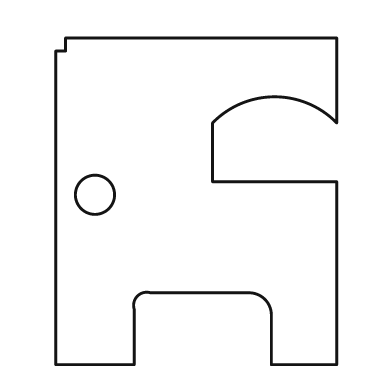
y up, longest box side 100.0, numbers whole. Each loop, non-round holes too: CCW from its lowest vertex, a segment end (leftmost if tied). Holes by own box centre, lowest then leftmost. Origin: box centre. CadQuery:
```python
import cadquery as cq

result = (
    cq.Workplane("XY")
    .moveTo(-43.0, -50.0)
    .lineTo(-19.0, -50.0)
    .lineTo(-19.0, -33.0)
    .threePointArc((-18.0, -29.0), (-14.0, -28.0))
    .lineTo(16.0, -28.0)
    .threePointArc((21.0, -30.0), (23.0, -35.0))
    .lineTo(23.0, -50.0)
    .lineTo(43.0, -50.0)
    .lineTo(43.0, 6.0)
    .lineTo(5.0, 6.0)
    .lineTo(5.0, 24.0)
    .threePointArc((24.0, 32.0), (43.0, 24.0))
    .lineTo(43.0, 50.0)
    .lineTo(-40.0, 50.0)
    .lineTo(-40.0, 46.0)
    .lineTo(-43.0, 46.0)
    .close()
    .moveTo(-31.0, 2.0)
    .circle(6.0)
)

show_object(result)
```